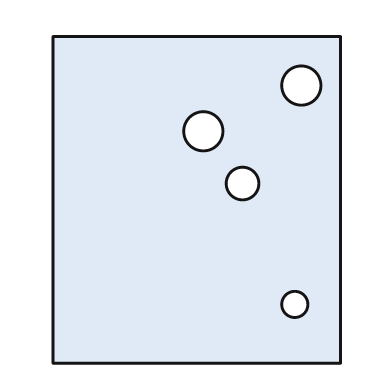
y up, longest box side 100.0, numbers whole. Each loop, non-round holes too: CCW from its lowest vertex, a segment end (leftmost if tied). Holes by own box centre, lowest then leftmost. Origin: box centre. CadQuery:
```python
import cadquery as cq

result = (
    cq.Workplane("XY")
    .moveTo(-44.0, -50.0)
    .lineTo(44.0, -50.0)
    .lineTo(44.0, 50.0)
    .lineTo(-44.0, 50.0)
    .close()
    .moveTo(30.0, -32.0)
    .circle(4.0)
    .moveTo(14.0, 5.0)
    .circle(5.0)
    .moveTo(2.0, 21.0)
    .circle(6.0)
    .moveTo(32.0, 35.0)
    .circle(6.0)
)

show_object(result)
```